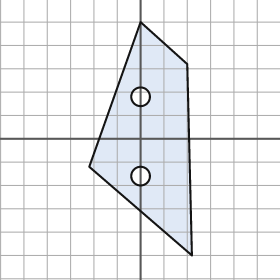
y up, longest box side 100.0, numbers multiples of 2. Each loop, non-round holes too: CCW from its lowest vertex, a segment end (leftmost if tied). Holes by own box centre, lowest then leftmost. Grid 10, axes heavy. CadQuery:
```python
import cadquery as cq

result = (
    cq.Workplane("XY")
    .moveTo(22.0, -50.0)
    .lineTo(20.0, 32.0)
    .lineTo(0.0, 50.0)
    .lineTo(-22.0, -12.0)
    .close()
    .moveTo(0.0, -16.0)
    .circle(4.0)
    .moveTo(0.0, 18.0)
    .circle(4.0)
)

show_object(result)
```